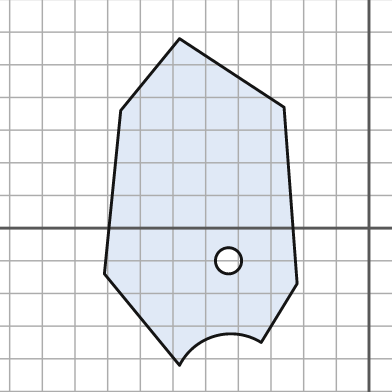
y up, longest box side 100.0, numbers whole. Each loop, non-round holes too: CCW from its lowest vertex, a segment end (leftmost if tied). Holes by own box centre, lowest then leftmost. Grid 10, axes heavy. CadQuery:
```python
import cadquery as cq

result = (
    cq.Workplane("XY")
    .moveTo(-58.0, -42.0)
    .threePointArc((-47.0, -33.0), (-33.0, -35.0))
    .lineTo(-22.0, -17.0)
    .lineTo(-26.0, 37.0)
    .lineTo(-58.0, 58.0)
    .lineTo(-76.0, 36.0)
    .lineTo(-81.0, -14.0)
    .close()
    .moveTo(-43.0, -10.0)
    .circle(4.0)
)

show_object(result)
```